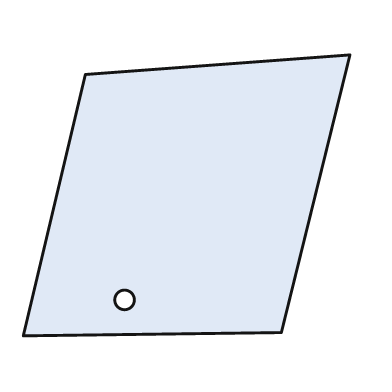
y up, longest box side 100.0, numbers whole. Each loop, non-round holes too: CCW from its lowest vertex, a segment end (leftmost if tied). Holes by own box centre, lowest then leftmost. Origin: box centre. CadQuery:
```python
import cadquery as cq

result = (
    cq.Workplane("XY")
    .moveTo(-50.0, -43.0)
    .lineTo(29.0, -42.0)
    .lineTo(50.0, 43.0)
    .lineTo(-31.0, 37.0)
    .close()
    .moveTo(-19.0, -32.0)
    .circle(3.0)
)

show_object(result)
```